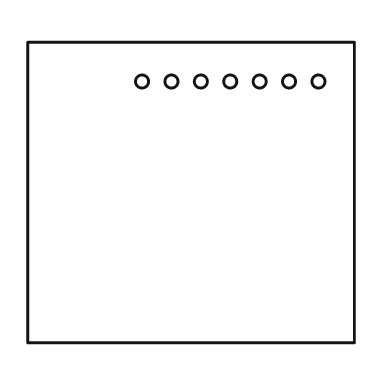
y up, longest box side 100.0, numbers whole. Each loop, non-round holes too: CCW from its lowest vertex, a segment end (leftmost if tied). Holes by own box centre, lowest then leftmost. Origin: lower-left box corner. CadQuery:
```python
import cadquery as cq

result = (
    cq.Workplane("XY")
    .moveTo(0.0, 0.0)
    .lineTo(100.0, 0.0)
    .lineTo(100.0, 92.0)
    .lineTo(0.0, 92.0)
    .close()
    .moveTo(35.0, 80.0)
    .circle(2.0)
    .moveTo(44.0, 80.0)
    .circle(2.0)
    .moveTo(53.0, 80.0)
    .circle(2.0)
    .moveTo(62.0, 80.0)
    .circle(2.0)
    .moveTo(71.0, 80.0)
    .circle(2.0)
    .moveTo(80.0, 80.0)
    .circle(2.0)
    .moveTo(89.0, 80.0)
    .circle(2.0)
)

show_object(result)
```